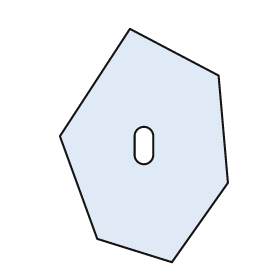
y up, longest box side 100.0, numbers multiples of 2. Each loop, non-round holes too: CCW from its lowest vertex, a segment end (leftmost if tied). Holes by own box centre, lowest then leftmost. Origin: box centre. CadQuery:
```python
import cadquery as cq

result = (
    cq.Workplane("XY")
    .moveTo(12.0, -50.0)
    .lineTo(36.0, -16.0)
    .lineTo(32.0, 30.0)
    .lineTo(-6.0, 50.0)
    .lineTo(-36.0, 4.0)
    .lineTo(-20.0, -40.0)
    .close()
    .moveTo(-4.0, -4.0)
    .threePointArc((0.0, -8.0), (4.0, -4.0))
    .lineTo(4.0, 4.0)
    .threePointArc((0.0, 8.0), (-4.0, 4.0))
    .close()
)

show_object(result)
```